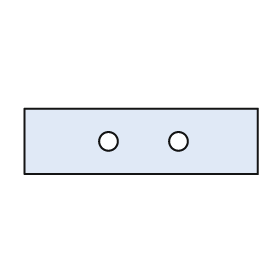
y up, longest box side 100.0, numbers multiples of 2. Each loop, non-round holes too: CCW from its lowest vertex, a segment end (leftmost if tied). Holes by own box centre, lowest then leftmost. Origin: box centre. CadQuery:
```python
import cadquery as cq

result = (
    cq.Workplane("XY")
    .moveTo(-50.0, -14.0)
    .lineTo(50.0, -14.0)
    .lineTo(50.0, 14.0)
    .lineTo(-50.0, 14.0)
    .close()
    .moveTo(-14.0, 0.0)
    .circle(4.0)
    .moveTo(16.0, 0.0)
    .circle(4.0)
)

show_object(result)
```